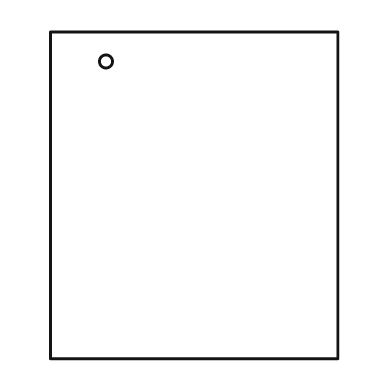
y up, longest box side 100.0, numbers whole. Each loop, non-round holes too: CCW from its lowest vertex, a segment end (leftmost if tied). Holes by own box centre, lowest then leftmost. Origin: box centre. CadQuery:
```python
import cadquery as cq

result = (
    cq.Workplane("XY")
    .moveTo(-44.0, -50.0)
    .lineTo(44.0, -50.0)
    .lineTo(44.0, 50.0)
    .lineTo(-44.0, 50.0)
    .close()
    .moveTo(-27.0, 41.0)
    .circle(2.0)
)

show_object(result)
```